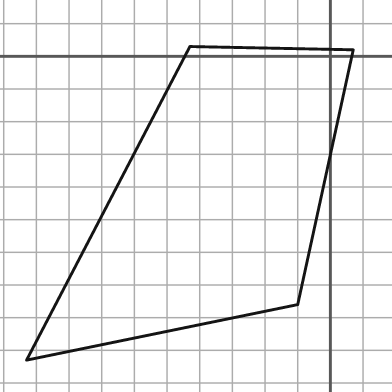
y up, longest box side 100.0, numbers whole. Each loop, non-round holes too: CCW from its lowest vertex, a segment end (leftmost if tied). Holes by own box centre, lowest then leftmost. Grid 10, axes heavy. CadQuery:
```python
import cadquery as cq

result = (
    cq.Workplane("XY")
    .moveTo(-93.0, -93.0)
    .lineTo(-10.0, -76.0)
    .lineTo(7.0, 2.0)
    .lineTo(-43.0, 3.0)
    .close()
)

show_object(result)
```